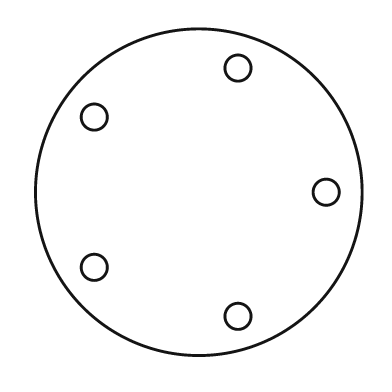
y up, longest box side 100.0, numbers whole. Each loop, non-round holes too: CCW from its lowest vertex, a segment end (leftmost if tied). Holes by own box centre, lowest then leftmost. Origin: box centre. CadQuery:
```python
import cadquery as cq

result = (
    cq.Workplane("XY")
    .moveTo(0.0, 0.0)
    .circle(50.0)
    .moveTo(12.0, -38.0)
    .circle(4.0)
    .moveTo(-32.0, -23.0)
    .circle(4.0)
    .moveTo(39.0, 0.0)
    .circle(4.0)
    .moveTo(-32.0, 23.0)
    .circle(4.0)
    .moveTo(12.0, 38.0)
    .circle(4.0)
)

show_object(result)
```